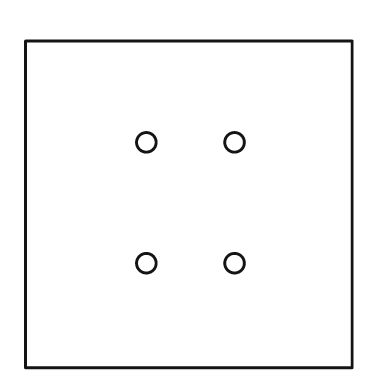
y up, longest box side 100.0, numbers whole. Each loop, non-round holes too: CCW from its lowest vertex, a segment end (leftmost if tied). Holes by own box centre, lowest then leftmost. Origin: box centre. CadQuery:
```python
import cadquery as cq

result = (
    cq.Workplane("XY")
    .moveTo(-50.0, -50.0)
    .lineTo(50.0, -50.0)
    .lineTo(50.0, 50.0)
    .lineTo(-50.0, 50.0)
    .close()
    .moveTo(-13.0, -18.0)
    .circle(3.0)
    .moveTo(14.0, -18.0)
    .circle(3.0)
    .moveTo(-13.0, 19.0)
    .circle(3.0)
    .moveTo(14.0, 19.0)
    .circle(3.0)
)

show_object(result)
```